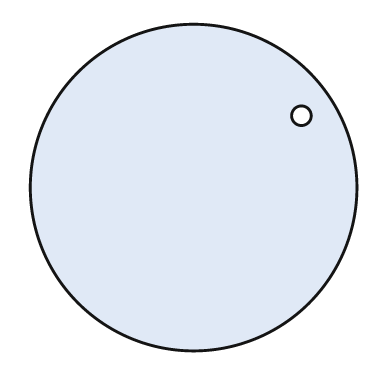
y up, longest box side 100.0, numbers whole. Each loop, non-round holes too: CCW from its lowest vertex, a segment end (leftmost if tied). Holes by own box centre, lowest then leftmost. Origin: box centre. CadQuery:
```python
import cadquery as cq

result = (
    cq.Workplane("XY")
    .moveTo(0.0, 0.0)
    .circle(50.0)
    .moveTo(33.0, 22.0)
    .circle(3.0)
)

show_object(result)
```